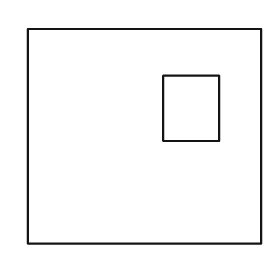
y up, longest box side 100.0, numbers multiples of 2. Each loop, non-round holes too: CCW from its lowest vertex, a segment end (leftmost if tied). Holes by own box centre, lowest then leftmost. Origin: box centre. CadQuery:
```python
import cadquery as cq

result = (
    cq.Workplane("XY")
    .moveTo(-50.0, -46.0)
    .lineTo(50.0, -46.0)
    .lineTo(50.0, 46.0)
    .lineTo(-50.0, 46.0)
    .close()
    .moveTo(8.0, -2.0)
    .lineTo(32.0, -2.0)
    .lineTo(32.0, 26.0)
    .lineTo(8.0, 26.0)
    .close()
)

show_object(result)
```